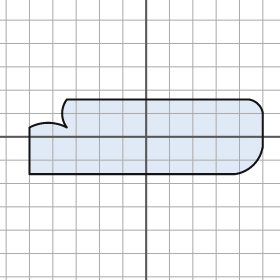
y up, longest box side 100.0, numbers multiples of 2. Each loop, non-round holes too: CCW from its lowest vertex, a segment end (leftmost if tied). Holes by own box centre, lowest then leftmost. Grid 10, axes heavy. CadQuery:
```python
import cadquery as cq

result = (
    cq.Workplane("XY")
    .moveTo(-50.0, -16.0)
    .lineTo(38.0, -16.0)
    .threePointArc((46.0, -12.0), (50.0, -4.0))
    .lineTo(50.0, 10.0)
    .threePointArc((48.0, 14.0), (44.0, 16.0))
    .lineTo(-34.0, 16.0)
    .threePointArc((-36.0, 10.0), (-34.0, 4.0))
    .threePointArc((-42.0, 6.0), (-50.0, 4.0))
    .close()
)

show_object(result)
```